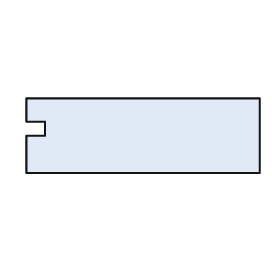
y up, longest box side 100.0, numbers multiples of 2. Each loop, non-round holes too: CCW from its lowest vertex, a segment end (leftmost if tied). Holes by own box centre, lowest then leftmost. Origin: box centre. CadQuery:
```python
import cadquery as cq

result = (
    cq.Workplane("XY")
    .moveTo(-50.0, -16.0)
    .lineTo(50.0, -16.0)
    .lineTo(50.0, 16.0)
    .lineTo(-50.0, 16.0)
    .lineTo(-50.0, 6.0)
    .lineTo(-42.0, 6.0)
    .lineTo(-42.0, 0.0)
    .lineTo(-50.0, 0.0)
    .close()
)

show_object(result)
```